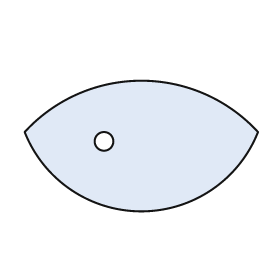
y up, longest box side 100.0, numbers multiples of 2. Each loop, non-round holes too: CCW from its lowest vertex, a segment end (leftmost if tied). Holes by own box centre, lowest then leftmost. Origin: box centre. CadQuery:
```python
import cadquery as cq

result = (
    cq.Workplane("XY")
    .moveTo(-50.0, 6.0)
    .threePointArc((0.0, -28.0), (50.0, 6.0))
    .threePointArc((0.0, 28.0), (-50.0, 6.0))
    .close()
    .moveTo(-16.0, 2.0)
    .circle(4.0)
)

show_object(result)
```